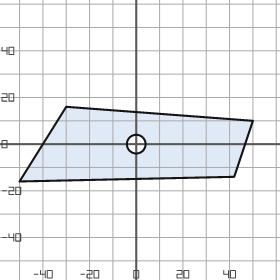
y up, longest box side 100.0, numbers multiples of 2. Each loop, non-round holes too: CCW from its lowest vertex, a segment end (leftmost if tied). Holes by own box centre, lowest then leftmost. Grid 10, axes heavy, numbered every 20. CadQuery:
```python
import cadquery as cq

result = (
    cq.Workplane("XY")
    .moveTo(-50.0, -16.0)
    .lineTo(42.0, -14.0)
    .lineTo(50.0, 10.0)
    .lineTo(-30.0, 16.0)
    .close()
    .moveTo(0.0, 0.0)
    .circle(4.0)
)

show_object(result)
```